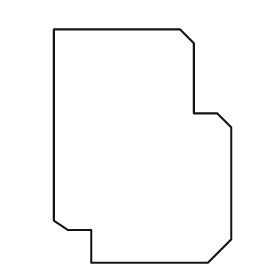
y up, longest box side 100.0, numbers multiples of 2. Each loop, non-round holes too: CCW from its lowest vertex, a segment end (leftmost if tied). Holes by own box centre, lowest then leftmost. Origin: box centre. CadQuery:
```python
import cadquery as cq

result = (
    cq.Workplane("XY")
    .moveTo(-22.0, -50.0)
    .lineTo(28.0, -50.0)
    .lineTo(38.0, -40.0)
    .lineTo(38.0, 8.0)
    .lineTo(32.0, 14.0)
    .lineTo(22.0, 14.0)
    .lineTo(22.0, 44.0)
    .lineTo(16.0, 50.0)
    .lineTo(-38.0, 50.0)
    .lineTo(-38.0, -32.0)
    .lineTo(-32.0, -36.0)
    .lineTo(-22.0, -36.0)
    .close()
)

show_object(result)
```